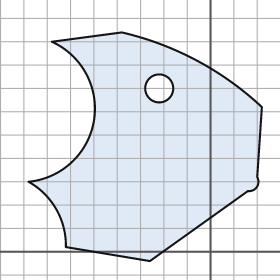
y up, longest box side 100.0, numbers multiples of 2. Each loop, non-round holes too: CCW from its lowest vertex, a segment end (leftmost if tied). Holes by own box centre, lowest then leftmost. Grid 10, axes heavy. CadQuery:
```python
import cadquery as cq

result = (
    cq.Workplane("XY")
    .moveTo(-26.0, -4.0)
    .lineTo(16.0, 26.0)
    .threePointArc((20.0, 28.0), (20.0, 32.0))
    .lineTo(22.0, 62.0)
    .threePointArc((-6.0, 82.0), (-38.0, 94.0))
    .lineTo(-68.0, 90.0)
    .threePointArc((-50.0, 56.0), (-78.0, 30.0))
    .threePointArc((-66.0, 18.0), (-62.0, 2.0))
    .close()
    .moveTo(-22.0, 70.0)
    .circle(6.0)
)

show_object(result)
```